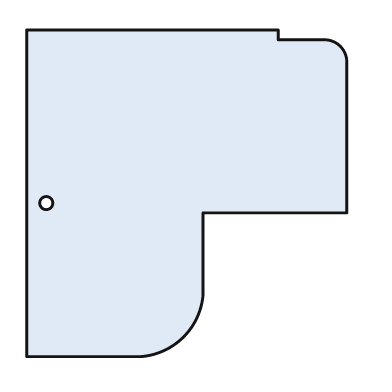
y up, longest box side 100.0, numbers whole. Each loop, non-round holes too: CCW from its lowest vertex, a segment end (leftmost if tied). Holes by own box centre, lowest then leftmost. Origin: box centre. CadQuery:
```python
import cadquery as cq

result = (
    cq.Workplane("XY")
    .moveTo(-49.0, -50.0)
    .lineTo(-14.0, -50.0)
    .threePointArc((-1.0, -44.0), (5.0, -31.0))
    .lineTo(5.0, -6.0)
    .lineTo(49.0, -6.0)
    .lineTo(49.0, 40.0)
    .threePointArc((47.0, 45.0), (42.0, 47.0))
    .lineTo(28.0, 47.0)
    .lineTo(28.0, 50.0)
    .lineTo(-49.0, 50.0)
    .close()
    .moveTo(-43.0, -3.0)
    .circle(2.0)
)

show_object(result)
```